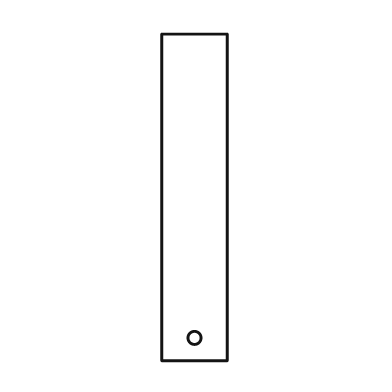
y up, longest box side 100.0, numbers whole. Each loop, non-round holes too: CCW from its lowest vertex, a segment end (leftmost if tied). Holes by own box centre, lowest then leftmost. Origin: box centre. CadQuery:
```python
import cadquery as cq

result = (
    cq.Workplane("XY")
    .moveTo(-10.0, -50.0)
    .lineTo(10.0, -50.0)
    .lineTo(10.0, 50.0)
    .lineTo(-10.0, 50.0)
    .close()
    .moveTo(0.0, -43.0)
    .circle(2.0)
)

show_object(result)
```